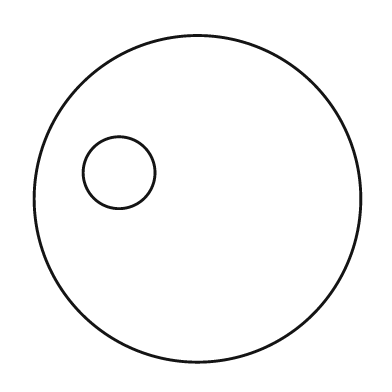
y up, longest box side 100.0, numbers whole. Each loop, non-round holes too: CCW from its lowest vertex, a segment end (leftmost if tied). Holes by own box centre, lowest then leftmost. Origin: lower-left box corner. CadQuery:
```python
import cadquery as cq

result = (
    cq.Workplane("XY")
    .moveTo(50.0, 50.0)
    .circle(50.0)
    .moveTo(26.0, 58.0)
    .circle(11.0)
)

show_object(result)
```